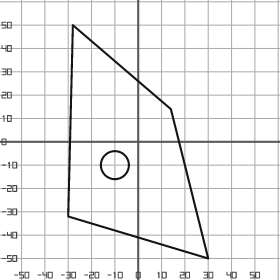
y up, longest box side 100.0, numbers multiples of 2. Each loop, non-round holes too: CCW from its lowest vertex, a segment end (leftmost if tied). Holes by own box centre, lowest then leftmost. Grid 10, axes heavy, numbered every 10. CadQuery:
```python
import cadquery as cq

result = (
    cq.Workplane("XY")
    .moveTo(30.0, -50.0)
    .lineTo(14.0, 14.0)
    .lineTo(-28.0, 50.0)
    .lineTo(-30.0, -32.0)
    .close()
    .moveTo(-10.0, -10.0)
    .circle(6.0)
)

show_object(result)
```